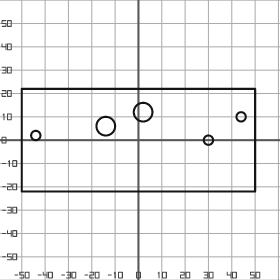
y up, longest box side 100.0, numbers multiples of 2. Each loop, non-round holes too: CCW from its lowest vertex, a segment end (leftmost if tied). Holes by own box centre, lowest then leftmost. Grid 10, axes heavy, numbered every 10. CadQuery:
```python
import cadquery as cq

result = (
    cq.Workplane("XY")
    .moveTo(-50.0, -22.0)
    .lineTo(50.0, -22.0)
    .lineTo(50.0, 22.0)
    .lineTo(-50.0, 22.0)
    .close()
    .moveTo(30.0, 0.0)
    .circle(2.0)
    .moveTo(-44.0, 2.0)
    .circle(2.0)
    .moveTo(-14.0, 6.0)
    .circle(4.0)
    .moveTo(44.0, 10.0)
    .circle(2.0)
    .moveTo(2.0, 12.0)
    .circle(4.0)
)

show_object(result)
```